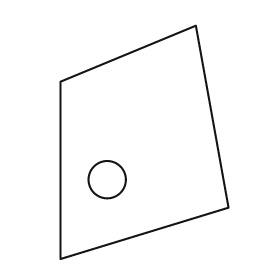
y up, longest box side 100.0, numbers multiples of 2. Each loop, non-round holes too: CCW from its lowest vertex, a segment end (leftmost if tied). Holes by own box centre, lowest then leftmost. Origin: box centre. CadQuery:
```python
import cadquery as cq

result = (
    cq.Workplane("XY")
    .moveTo(-36.0, -50.0)
    .lineTo(36.0, -28.0)
    .lineTo(22.0, 50.0)
    .lineTo(-36.0, 26.0)
    .close()
    .moveTo(-16.0, -16.0)
    .circle(8.0)
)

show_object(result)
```